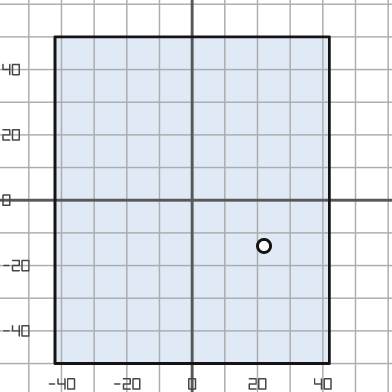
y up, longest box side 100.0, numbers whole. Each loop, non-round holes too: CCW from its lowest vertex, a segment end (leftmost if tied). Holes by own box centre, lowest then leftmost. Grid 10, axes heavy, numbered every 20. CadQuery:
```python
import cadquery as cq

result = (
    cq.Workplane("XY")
    .moveTo(-42.0, -50.0)
    .lineTo(42.0, -50.0)
    .lineTo(42.0, 50.0)
    .lineTo(-42.0, 50.0)
    .close()
    .moveTo(22.0, -14.0)
    .circle(2.0)
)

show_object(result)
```